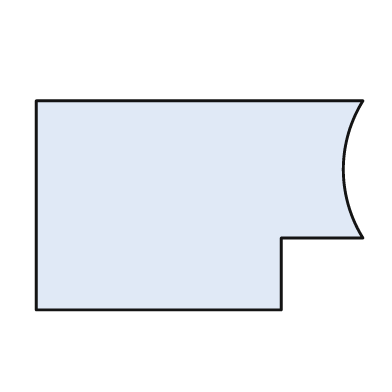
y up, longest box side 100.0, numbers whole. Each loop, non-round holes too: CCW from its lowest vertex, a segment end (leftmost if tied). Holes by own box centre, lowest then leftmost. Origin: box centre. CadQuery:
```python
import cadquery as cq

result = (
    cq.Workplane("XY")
    .moveTo(-50.0, -32.0)
    .lineTo(25.0, -32.0)
    .lineTo(25.0, -10.0)
    .lineTo(50.0, -10.0)
    .threePointArc((44.0, 11.0), (50.0, 32.0))
    .lineTo(-50.0, 32.0)
    .close()
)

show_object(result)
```